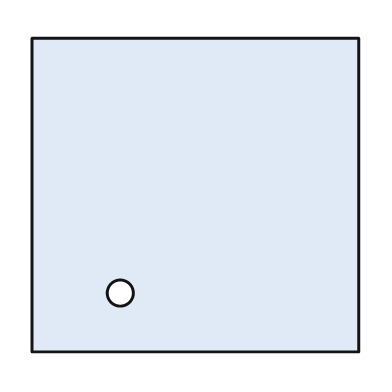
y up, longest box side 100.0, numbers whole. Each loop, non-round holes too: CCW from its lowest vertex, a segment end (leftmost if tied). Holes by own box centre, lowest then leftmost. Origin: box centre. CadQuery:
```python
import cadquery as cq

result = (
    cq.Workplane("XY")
    .moveTo(-50.0, -48.0)
    .lineTo(50.0, -48.0)
    .lineTo(50.0, 48.0)
    .lineTo(-50.0, 48.0)
    .close()
    .moveTo(-23.0, -30.0)
    .circle(4.0)
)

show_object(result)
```